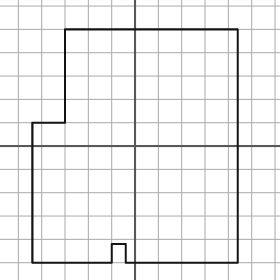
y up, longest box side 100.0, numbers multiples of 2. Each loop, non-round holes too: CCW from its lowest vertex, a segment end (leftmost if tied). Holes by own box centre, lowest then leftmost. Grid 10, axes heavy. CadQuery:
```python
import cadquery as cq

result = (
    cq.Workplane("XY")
    .moveTo(-44.0, -50.0)
    .lineTo(-10.0, -50.0)
    .lineTo(-10.0, -42.0)
    .lineTo(-4.0, -42.0)
    .lineTo(-4.0, -50.0)
    .lineTo(44.0, -50.0)
    .lineTo(44.0, 50.0)
    .lineTo(-30.0, 50.0)
    .lineTo(-30.0, 10.0)
    .lineTo(-44.0, 10.0)
    .close()
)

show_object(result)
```